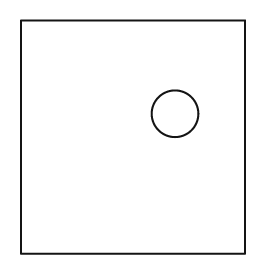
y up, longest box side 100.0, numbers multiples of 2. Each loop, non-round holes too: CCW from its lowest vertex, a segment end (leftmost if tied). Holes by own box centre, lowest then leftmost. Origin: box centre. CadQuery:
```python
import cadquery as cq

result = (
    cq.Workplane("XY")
    .moveTo(-48.0, -50.0)
    .lineTo(48.0, -50.0)
    .lineTo(48.0, 50.0)
    .lineTo(-48.0, 50.0)
    .close()
    .moveTo(18.0, 10.0)
    .circle(10.0)
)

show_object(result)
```